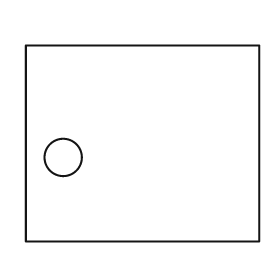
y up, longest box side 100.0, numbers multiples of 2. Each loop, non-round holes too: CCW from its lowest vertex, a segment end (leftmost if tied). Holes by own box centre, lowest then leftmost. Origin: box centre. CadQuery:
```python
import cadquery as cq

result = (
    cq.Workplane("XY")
    .moveTo(-50.0, -42.0)
    .lineTo(50.0, -42.0)
    .lineTo(50.0, 42.0)
    .lineTo(-50.0, 42.0)
    .close()
    .moveTo(-34.0, -6.0)
    .circle(8.0)
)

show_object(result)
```